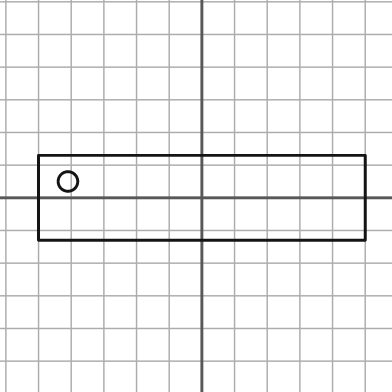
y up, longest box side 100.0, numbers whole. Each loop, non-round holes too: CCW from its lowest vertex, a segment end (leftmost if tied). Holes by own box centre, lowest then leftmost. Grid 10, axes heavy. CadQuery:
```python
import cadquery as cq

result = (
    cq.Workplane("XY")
    .moveTo(-50.0, -13.0)
    .lineTo(50.0, -13.0)
    .lineTo(50.0, 13.0)
    .lineTo(-50.0, 13.0)
    .close()
    .moveTo(-41.0, 5.0)
    .circle(3.0)
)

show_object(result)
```